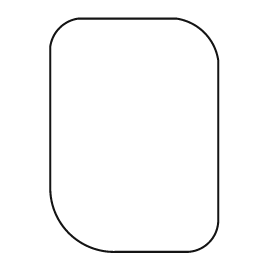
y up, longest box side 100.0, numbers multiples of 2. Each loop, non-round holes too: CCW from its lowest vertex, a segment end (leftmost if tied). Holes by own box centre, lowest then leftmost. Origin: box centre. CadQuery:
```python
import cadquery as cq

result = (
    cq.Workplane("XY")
    .moveTo(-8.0, -50.0)
    .lineTo(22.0, -50.0)
    .threePointArc((32.0, -46.0), (36.0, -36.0))
    .lineTo(36.0, 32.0)
    .threePointArc((30.0, 44.0), (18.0, 50.0))
    .lineTo(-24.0, 50.0)
    .threePointArc((-32.0, 46.0), (-36.0, 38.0))
    .lineTo(-36.0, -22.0)
    .threePointArc((-28.0, -42.0), (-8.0, -50.0))
    .close()
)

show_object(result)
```